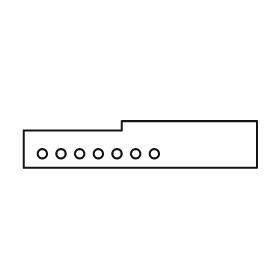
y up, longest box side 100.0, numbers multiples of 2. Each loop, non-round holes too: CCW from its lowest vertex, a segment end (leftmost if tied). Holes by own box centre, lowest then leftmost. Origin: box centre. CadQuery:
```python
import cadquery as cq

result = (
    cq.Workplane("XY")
    .moveTo(-50.0, -10.0)
    .lineTo(50.0, -10.0)
    .lineTo(50.0, 10.0)
    .lineTo(-8.0, 10.0)
    .lineTo(-8.0, 6.0)
    .lineTo(-50.0, 6.0)
    .close()
    .moveTo(-42.0, -4.0)
    .circle(2.0)
    .moveTo(-34.0, -4.0)
    .circle(2.0)
    .moveTo(-26.0, -4.0)
    .circle(2.0)
    .moveTo(-18.0, -4.0)
    .circle(2.0)
    .moveTo(-10.0, -4.0)
    .circle(2.0)
    .moveTo(-2.0, -4.0)
    .circle(2.0)
    .moveTo(6.0, -4.0)
    .circle(2.0)
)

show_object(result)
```